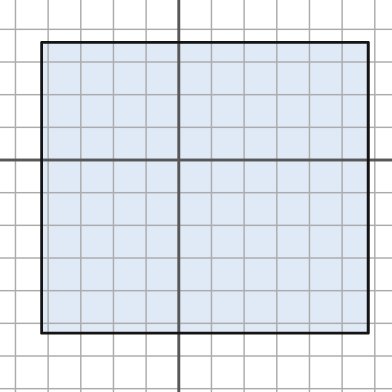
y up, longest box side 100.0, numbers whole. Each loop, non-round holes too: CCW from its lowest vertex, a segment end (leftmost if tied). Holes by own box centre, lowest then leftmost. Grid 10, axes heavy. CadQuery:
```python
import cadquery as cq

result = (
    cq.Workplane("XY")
    .moveTo(-42.0, -53.0)
    .lineTo(58.0, -53.0)
    .lineTo(58.0, 36.0)
    .lineTo(-42.0, 36.0)
    .close()
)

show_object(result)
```